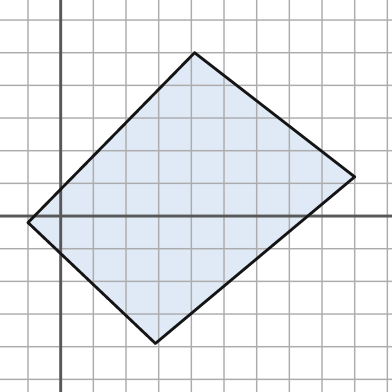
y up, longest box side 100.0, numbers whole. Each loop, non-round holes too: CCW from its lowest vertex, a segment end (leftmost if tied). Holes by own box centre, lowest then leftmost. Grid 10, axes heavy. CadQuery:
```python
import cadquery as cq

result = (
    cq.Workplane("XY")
    .moveTo(29.0, -39.0)
    .lineTo(90.0, 12.0)
    .lineTo(41.0, 50.0)
    .lineTo(-10.0, -2.0)
    .close()
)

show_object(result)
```